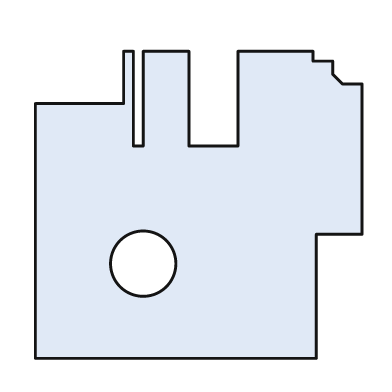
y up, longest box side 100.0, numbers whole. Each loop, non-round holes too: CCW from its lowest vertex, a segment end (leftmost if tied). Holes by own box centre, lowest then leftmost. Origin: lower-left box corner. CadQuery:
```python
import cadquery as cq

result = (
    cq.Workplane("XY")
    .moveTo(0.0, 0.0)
    .lineTo(86.0, 0.0)
    .lineTo(86.0, 38.0)
    .lineTo(100.0, 38.0)
    .lineTo(100.0, 84.0)
    .lineTo(94.0, 84.0)
    .lineTo(91.0, 87.0)
    .lineTo(91.0, 91.0)
    .lineTo(85.0, 91.0)
    .lineTo(85.0, 94.0)
    .lineTo(62.0, 94.0)
    .lineTo(62.0, 65.0)
    .lineTo(47.0, 65.0)
    .lineTo(47.0, 94.0)
    .lineTo(33.0, 94.0)
    .lineTo(33.0, 65.0)
    .lineTo(30.0, 65.0)
    .lineTo(30.0, 94.0)
    .lineTo(27.0, 94.0)
    .lineTo(27.0, 78.0)
    .lineTo(0.0, 78.0)
    .close()
    .moveTo(33.0, 29.0)
    .circle(10.0)
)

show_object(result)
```